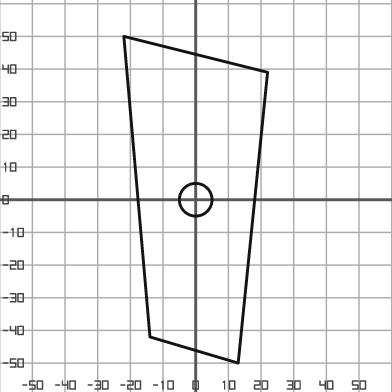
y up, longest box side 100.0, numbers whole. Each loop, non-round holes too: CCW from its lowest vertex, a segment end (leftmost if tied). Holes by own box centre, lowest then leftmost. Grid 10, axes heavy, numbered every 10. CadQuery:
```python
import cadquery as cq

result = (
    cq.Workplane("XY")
    .moveTo(13.0, -50.0)
    .lineTo(22.0, 39.0)
    .lineTo(-22.0, 50.0)
    .lineTo(-14.0, -42.0)
    .close()
    .moveTo(0.0, 0.0)
    .circle(5.0)
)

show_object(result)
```